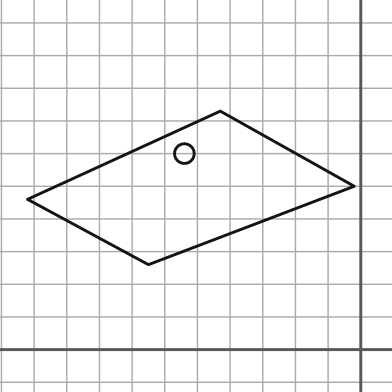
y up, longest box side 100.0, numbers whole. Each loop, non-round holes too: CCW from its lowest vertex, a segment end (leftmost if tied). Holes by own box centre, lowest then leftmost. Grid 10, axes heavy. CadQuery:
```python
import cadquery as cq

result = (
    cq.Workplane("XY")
    .moveTo(-65.0, 26.0)
    .lineTo(-2.0, 50.0)
    .lineTo(-43.0, 73.0)
    .lineTo(-102.0, 46.0)
    .close()
    .moveTo(-54.0, 60.0)
    .circle(3.0)
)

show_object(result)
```